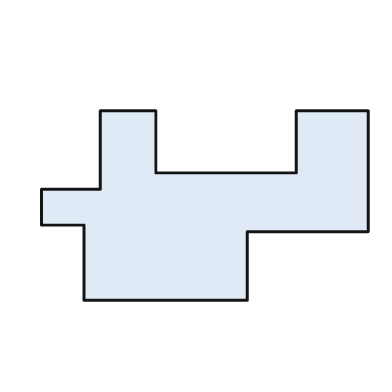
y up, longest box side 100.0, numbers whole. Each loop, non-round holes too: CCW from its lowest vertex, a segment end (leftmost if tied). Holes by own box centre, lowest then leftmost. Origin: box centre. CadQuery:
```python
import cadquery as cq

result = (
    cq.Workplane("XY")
    .moveTo(-37.0, -29.0)
    .lineTo(13.0, -29.0)
    .lineTo(13.0, -8.0)
    .lineTo(50.0, -8.0)
    .lineTo(50.0, 29.0)
    .lineTo(28.0, 29.0)
    .lineTo(28.0, 10.0)
    .lineTo(-15.0, 10.0)
    .lineTo(-15.0, 29.0)
    .lineTo(-32.0, 29.0)
    .lineTo(-32.0, 5.0)
    .lineTo(-50.0, 5.0)
    .lineTo(-50.0, -6.0)
    .lineTo(-37.0, -6.0)
    .close()
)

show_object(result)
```